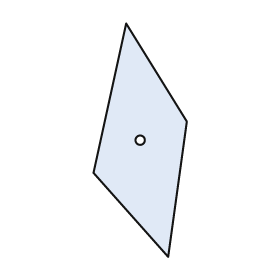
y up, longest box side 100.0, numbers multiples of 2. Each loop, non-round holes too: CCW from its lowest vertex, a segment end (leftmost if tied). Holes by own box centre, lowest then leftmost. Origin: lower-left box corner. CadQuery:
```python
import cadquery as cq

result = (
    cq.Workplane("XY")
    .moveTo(32.0, 0.0)
    .lineTo(40.0, 58.0)
    .lineTo(14.0, 100.0)
    .lineTo(0.0, 36.0)
    .close()
    .moveTo(20.0, 50.0)
    .circle(2.0)
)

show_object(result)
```